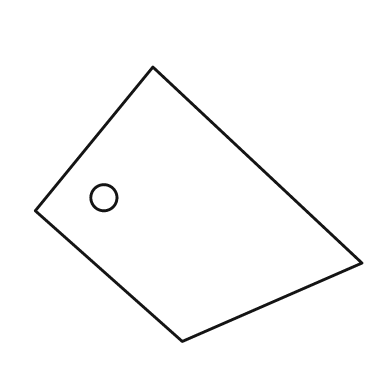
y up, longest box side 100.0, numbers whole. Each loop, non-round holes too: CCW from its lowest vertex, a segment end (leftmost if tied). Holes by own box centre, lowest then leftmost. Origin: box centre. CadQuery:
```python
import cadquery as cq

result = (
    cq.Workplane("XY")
    .moveTo(-5.0, -42.0)
    .lineTo(50.0, -18.0)
    .lineTo(-14.0, 42.0)
    .lineTo(-50.0, -2.0)
    .close()
    .moveTo(-29.0, 2.0)
    .circle(4.0)
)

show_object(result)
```